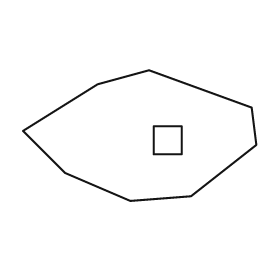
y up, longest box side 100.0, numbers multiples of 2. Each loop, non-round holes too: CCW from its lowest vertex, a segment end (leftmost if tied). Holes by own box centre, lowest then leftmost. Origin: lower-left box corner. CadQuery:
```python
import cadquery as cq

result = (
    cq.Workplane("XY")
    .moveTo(46.0, 0.0)
    .lineTo(72.0, 2.0)
    .lineTo(100.0, 24.0)
    .lineTo(98.0, 40.0)
    .lineTo(54.0, 56.0)
    .lineTo(32.0, 50.0)
    .lineTo(0.0, 30.0)
    .lineTo(18.0, 12.0)
    .close()
    .moveTo(56.0, 20.0)
    .lineTo(68.0, 20.0)
    .lineTo(68.0, 32.0)
    .lineTo(56.0, 32.0)
    .close()
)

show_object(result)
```